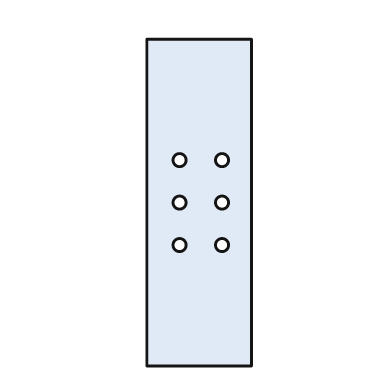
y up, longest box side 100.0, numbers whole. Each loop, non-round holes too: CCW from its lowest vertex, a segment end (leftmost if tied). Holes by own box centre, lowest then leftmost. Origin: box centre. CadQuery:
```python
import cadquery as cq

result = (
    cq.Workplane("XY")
    .moveTo(-16.0, -50.0)
    .lineTo(16.0, -50.0)
    .lineTo(16.0, 50.0)
    .lineTo(-16.0, 50.0)
    .close()
    .moveTo(-6.0, -13.0)
    .circle(2.0)
    .moveTo(7.0, -13.0)
    .circle(2.0)
    .moveTo(-6.0, 0.0)
    .circle(2.0)
    .moveTo(7.0, 0.0)
    .circle(2.0)
    .moveTo(-6.0, 13.0)
    .circle(2.0)
    .moveTo(7.0, 13.0)
    .circle(2.0)
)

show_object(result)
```